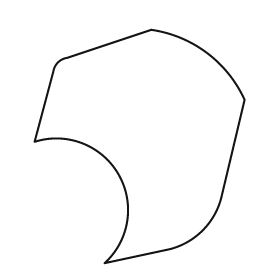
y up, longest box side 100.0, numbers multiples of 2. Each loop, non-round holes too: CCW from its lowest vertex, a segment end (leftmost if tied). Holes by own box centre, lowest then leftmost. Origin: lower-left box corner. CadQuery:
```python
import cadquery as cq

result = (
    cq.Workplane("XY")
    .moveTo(30.0, 0.0)
    .lineTo(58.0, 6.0)
    .threePointArc((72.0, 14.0), (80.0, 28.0))
    .lineTo(90.0, 70.0)
    .threePointArc((74.0, 90.0), (50.0, 100.0))
    .lineTo(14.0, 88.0)
    .threePointArc((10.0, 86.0), (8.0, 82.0))
    .lineTo(0.0, 52.0)
    .threePointArc((36.0, 38.0), (30.0, 0.0))
    .close()
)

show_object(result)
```